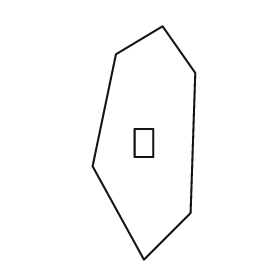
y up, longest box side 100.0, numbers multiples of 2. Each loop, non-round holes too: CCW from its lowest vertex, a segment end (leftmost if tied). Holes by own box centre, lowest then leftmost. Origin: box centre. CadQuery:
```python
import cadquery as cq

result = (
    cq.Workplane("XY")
    .moveTo(0.0, -50.0)
    .lineTo(20.0, -30.0)
    .lineTo(22.0, 30.0)
    .lineTo(8.0, 50.0)
    .lineTo(-12.0, 38.0)
    .lineTo(-22.0, -10.0)
    .close()
    .moveTo(-4.0, -6.0)
    .lineTo(4.0, -6.0)
    .lineTo(4.0, 6.0)
    .lineTo(-4.0, 6.0)
    .close()
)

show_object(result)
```